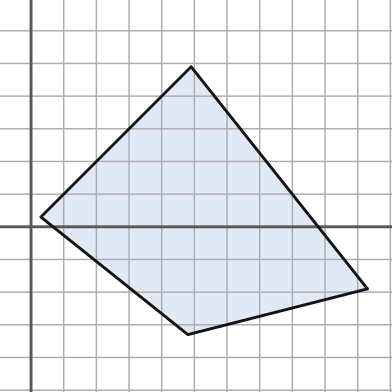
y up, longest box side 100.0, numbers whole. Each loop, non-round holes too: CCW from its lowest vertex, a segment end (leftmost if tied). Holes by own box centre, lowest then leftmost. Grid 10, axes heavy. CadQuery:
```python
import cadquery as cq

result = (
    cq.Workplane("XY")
    .moveTo(48.0, -33.0)
    .lineTo(103.0, -19.0)
    .lineTo(49.0, 49.0)
    .lineTo(3.0, 3.0)
    .close()
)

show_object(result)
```